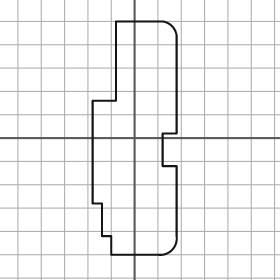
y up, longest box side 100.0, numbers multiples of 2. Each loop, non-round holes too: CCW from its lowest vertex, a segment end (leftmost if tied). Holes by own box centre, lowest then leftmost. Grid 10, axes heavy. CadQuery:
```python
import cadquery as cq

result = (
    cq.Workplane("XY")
    .moveTo(-10.0, -50.0)
    .lineTo(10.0, -50.0)
    .threePointArc((16.0, -48.0), (18.0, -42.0))
    .lineTo(18.0, -12.0)
    .lineTo(12.0, -12.0)
    .lineTo(12.0, 2.0)
    .lineTo(18.0, 2.0)
    .lineTo(18.0, 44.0)
    .threePointArc((16.0, 48.0), (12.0, 50.0))
    .lineTo(-8.0, 50.0)
    .lineTo(-8.0, 16.0)
    .lineTo(-18.0, 16.0)
    .lineTo(-18.0, -28.0)
    .lineTo(-14.0, -28.0)
    .lineTo(-14.0, -42.0)
    .lineTo(-10.0, -42.0)
    .close()
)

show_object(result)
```